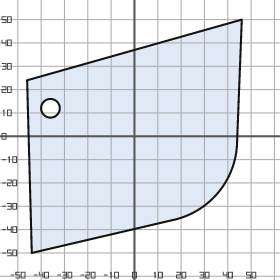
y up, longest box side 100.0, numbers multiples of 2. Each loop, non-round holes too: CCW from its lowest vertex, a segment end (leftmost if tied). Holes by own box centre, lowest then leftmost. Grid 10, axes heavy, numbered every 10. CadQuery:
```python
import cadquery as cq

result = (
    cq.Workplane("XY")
    .moveTo(-44.0, -50.0)
    .lineTo(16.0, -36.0)
    .threePointArc((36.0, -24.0), (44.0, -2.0))
    .lineTo(46.0, 50.0)
    .lineTo(-46.0, 24.0)
    .close()
    .moveTo(-36.0, 12.0)
    .circle(4.0)
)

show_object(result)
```